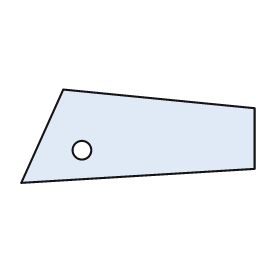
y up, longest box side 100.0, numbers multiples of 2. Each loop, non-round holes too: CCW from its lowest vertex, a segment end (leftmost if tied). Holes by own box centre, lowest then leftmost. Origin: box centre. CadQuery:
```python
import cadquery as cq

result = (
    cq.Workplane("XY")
    .moveTo(-50.0, -20.0)
    .lineTo(50.0, -14.0)
    .lineTo(50.0, 12.0)
    .lineTo(-32.0, 20.0)
    .close()
    .moveTo(-24.0, -6.0)
    .circle(4.0)
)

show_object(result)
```